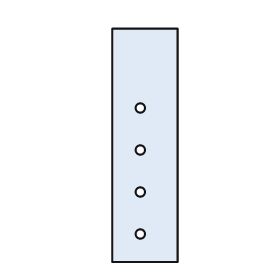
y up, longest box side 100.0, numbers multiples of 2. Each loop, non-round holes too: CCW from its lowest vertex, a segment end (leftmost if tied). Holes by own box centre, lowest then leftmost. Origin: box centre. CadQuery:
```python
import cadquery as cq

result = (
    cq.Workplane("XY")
    .moveTo(-14.0, -50.0)
    .lineTo(14.0, -50.0)
    .lineTo(14.0, 50.0)
    .lineTo(-14.0, 50.0)
    .close()
    .moveTo(-2.0, -38.0)
    .circle(2.0)
    .moveTo(-2.0, -20.0)
    .circle(2.0)
    .moveTo(-2.0, -2.0)
    .circle(2.0)
    .moveTo(-2.0, 16.0)
    .circle(2.0)
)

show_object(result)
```